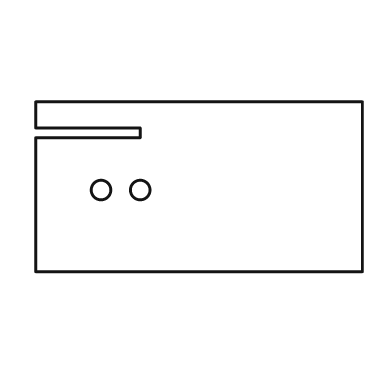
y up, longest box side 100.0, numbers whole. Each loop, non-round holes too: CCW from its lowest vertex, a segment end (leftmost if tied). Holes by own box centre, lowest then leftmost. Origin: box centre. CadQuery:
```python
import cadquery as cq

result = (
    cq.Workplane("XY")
    .moveTo(-50.0, -26.0)
    .lineTo(50.0, -26.0)
    .lineTo(50.0, 26.0)
    .lineTo(-50.0, 26.0)
    .lineTo(-50.0, 18.0)
    .lineTo(-18.0, 18.0)
    .lineTo(-18.0, 15.0)
    .lineTo(-50.0, 15.0)
    .close()
    .moveTo(-30.0, -1.0)
    .circle(3.0)
    .moveTo(-18.0, -1.0)
    .circle(3.0)
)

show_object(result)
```